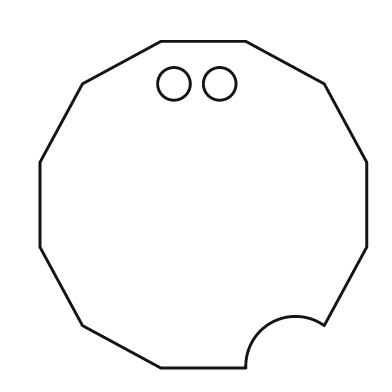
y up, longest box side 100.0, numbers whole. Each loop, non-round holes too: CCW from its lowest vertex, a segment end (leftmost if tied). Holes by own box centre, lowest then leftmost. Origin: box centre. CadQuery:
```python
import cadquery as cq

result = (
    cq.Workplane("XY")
    .moveTo(-13.0, -50.0)
    .lineTo(13.0, -50.0)
    .threePointArc((21.0, -36.0), (37.0, -37.0))
    .lineTo(50.0, -13.0)
    .lineTo(50.0, 13.0)
    .lineTo(37.0, 37.0)
    .lineTo(13.0, 50.0)
    .lineTo(-13.0, 50.0)
    .lineTo(-37.0, 37.0)
    .lineTo(-50.0, 13.0)
    .lineTo(-50.0, -13.0)
    .lineTo(-37.0, -37.0)
    .close()
    .moveTo(-9.0, 37.0)
    .circle(5.0)
    .moveTo(5.0, 37.0)
    .circle(5.0)
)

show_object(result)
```